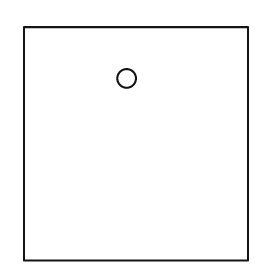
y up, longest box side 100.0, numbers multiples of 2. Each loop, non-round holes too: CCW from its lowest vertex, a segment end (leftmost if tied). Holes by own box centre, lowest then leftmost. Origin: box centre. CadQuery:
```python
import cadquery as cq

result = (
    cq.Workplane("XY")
    .moveTo(-48.0, -50.0)
    .lineTo(48.0, -50.0)
    .lineTo(48.0, 50.0)
    .lineTo(-48.0, 50.0)
    .close()
    .moveTo(-4.0, 28.0)
    .circle(4.0)
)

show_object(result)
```